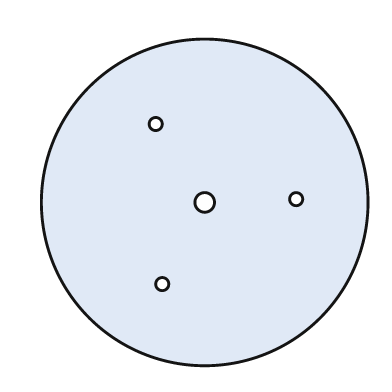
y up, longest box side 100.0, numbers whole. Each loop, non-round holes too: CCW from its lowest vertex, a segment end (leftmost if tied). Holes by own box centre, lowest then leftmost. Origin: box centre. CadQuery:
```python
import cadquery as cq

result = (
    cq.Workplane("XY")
    .moveTo(0.0, 0.0)
    .circle(50.0)
    .moveTo(-13.0, -25.0)
    .circle(2.0)
    .moveTo(0.0, 0.0)
    .circle(3.0)
    .moveTo(28.0, 1.0)
    .circle(2.0)
    .moveTo(-15.0, 24.0)
    .circle(2.0)
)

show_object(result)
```